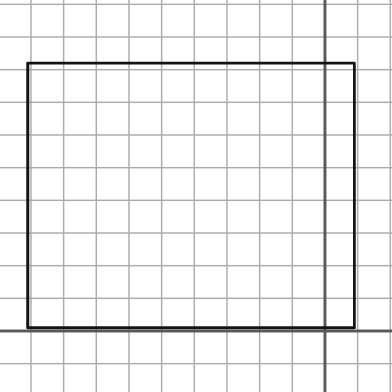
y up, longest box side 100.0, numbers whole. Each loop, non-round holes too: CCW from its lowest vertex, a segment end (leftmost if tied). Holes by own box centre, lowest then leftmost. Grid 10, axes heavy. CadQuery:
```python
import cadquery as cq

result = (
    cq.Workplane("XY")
    .moveTo(-91.0, 1.0)
    .lineTo(9.0, 1.0)
    .lineTo(9.0, 82.0)
    .lineTo(-91.0, 82.0)
    .close()
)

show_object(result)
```